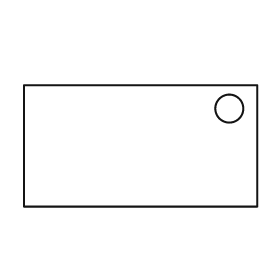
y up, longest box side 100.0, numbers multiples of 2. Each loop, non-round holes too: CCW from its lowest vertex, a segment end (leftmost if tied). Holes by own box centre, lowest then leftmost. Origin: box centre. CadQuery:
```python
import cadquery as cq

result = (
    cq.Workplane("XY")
    .moveTo(-50.0, -26.0)
    .lineTo(50.0, -26.0)
    .lineTo(50.0, 26.0)
    .lineTo(-50.0, 26.0)
    .close()
    .moveTo(38.0, 16.0)
    .circle(6.0)
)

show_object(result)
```